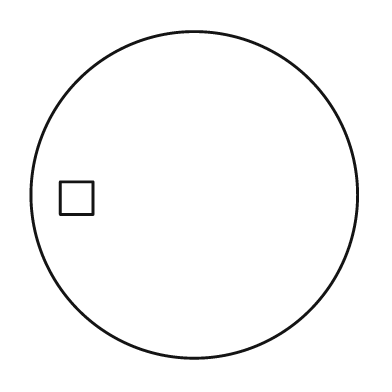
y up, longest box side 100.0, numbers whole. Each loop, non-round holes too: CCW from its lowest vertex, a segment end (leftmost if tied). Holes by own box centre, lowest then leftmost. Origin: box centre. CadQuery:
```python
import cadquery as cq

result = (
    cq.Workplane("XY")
    .moveTo(0.0, 0.0)
    .circle(50.0)
    .moveTo(-41.0, -6.0)
    .lineTo(-31.0, -6.0)
    .lineTo(-31.0, 4.0)
    .lineTo(-41.0, 4.0)
    .close()
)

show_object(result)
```